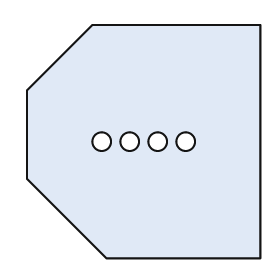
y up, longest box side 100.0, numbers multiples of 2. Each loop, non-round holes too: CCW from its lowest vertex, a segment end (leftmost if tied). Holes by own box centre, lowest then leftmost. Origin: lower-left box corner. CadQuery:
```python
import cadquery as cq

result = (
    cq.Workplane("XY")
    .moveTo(34.0, 0.0)
    .lineTo(100.0, 0.0)
    .lineTo(100.0, 100.0)
    .lineTo(28.0, 100.0)
    .lineTo(0.0, 72.0)
    .lineTo(0.0, 34.0)
    .close()
    .moveTo(32.0, 50.0)
    .circle(4.0)
    .moveTo(44.0, 50.0)
    .circle(4.0)
    .moveTo(56.0, 50.0)
    .circle(4.0)
    .moveTo(68.0, 50.0)
    .circle(4.0)
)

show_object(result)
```